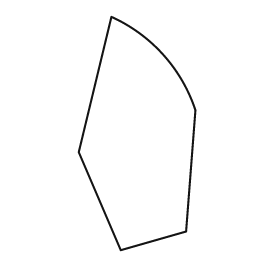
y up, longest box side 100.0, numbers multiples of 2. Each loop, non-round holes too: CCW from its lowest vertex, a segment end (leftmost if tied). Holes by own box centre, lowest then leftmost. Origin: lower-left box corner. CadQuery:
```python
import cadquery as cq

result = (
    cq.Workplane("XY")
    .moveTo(18.0, 0.0)
    .lineTo(46.0, 8.0)
    .lineTo(50.0, 60.0)
    .threePointArc((36.0, 84.0), (14.0, 100.0))
    .lineTo(0.0, 42.0)
    .close()
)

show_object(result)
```